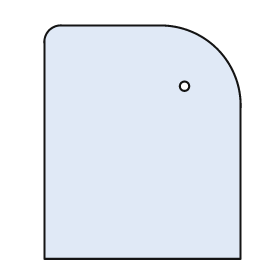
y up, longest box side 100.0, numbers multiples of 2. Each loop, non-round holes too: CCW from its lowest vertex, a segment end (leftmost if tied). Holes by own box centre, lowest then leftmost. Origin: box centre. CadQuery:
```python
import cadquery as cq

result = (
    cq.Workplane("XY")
    .moveTo(-42.0, -50.0)
    .lineTo(42.0, -50.0)
    .lineTo(42.0, 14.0)
    .threePointArc((32.0, 40.0), (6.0, 50.0))
    .lineTo(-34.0, 50.0)
    .threePointArc((-40.0, 48.0), (-42.0, 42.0))
    .close()
    .moveTo(18.0, 24.0)
    .circle(2.0)
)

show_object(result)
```